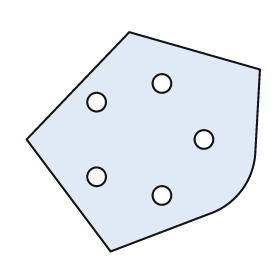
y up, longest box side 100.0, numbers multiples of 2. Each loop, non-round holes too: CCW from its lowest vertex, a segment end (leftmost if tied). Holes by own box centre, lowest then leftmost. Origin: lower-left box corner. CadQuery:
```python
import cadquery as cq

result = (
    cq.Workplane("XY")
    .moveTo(36.0, 0.0)
    .lineTo(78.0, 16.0)
    .threePointArc((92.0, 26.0), (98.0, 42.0))
    .lineTo(100.0, 78.0)
    .lineTo(44.0, 94.0)
    .lineTo(0.0, 48.0)
    .close()
    .moveTo(58.0, 24.0)
    .circle(4.0)
    .moveTo(30.0, 32.0)
    .circle(4.0)
    .moveTo(76.0, 48.0)
    .circle(4.0)
    .moveTo(30.0, 64.0)
    .circle(4.0)
    .moveTo(58.0, 72.0)
    .circle(4.0)
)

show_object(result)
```